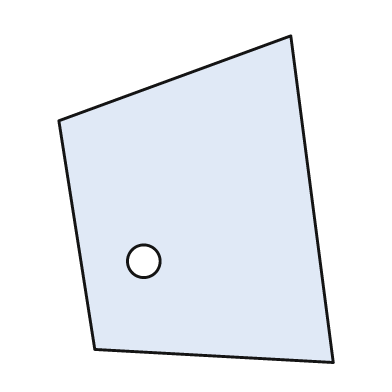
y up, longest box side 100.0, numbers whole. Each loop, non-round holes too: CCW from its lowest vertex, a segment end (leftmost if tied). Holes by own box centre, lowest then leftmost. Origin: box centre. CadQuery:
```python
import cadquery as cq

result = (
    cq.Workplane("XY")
    .moveTo(42.0, -50.0)
    .lineTo(29.0, 50.0)
    .lineTo(-42.0, 24.0)
    .lineTo(-31.0, -46.0)
    .close()
    .moveTo(-16.0, -19.0)
    .circle(5.0)
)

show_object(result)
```